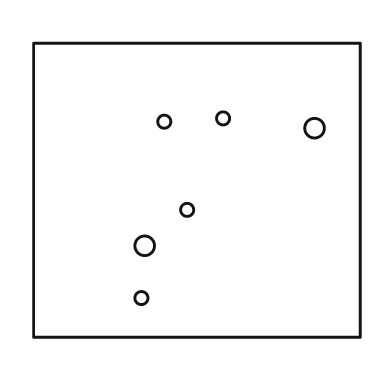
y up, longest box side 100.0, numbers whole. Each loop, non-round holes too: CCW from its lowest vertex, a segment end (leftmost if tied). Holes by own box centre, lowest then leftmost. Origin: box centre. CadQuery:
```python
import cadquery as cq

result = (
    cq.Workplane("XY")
    .moveTo(-50.0, -45.0)
    .lineTo(50.0, -45.0)
    .lineTo(50.0, 45.0)
    .lineTo(-50.0, 45.0)
    .close()
    .moveTo(-17.0, -33.0)
    .circle(2.0)
    .moveTo(-16.0, -17.0)
    .circle(3.0)
    .moveTo(-3.0, -6.0)
    .circle(2.0)
    .moveTo(36.0, 19.0)
    .circle(3.0)
    .moveTo(-10.0, 21.0)
    .circle(2.0)
    .moveTo(8.0, 22.0)
    .circle(2.0)
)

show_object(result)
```